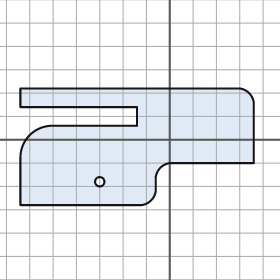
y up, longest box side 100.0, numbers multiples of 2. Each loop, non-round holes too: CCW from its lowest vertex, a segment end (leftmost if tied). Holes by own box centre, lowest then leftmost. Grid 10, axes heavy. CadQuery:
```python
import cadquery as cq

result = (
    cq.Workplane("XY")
    .moveTo(-64.0, -28.0)
    .lineTo(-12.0, -28.0)
    .threePointArc((-8.0, -26.0), (-6.0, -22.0))
    .lineTo(-6.0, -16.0)
    .threePointArc((-4.0, -12.0), (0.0, -10.0))
    .lineTo(36.0, -10.0)
    .lineTo(36.0, 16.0)
    .threePointArc((34.0, 20.0), (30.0, 22.0))
    .lineTo(-64.0, 22.0)
    .lineTo(-64.0, 14.0)
    .lineTo(-14.0, 14.0)
    .lineTo(-14.0, 6.0)
    .lineTo(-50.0, 6.0)
    .threePointArc((-60.0, 2.0), (-64.0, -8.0))
    .close()
    .moveTo(-30.0, -18.0)
    .circle(2.0)
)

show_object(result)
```